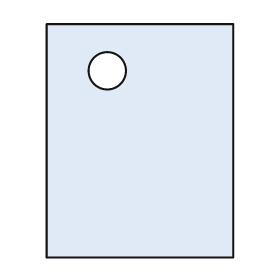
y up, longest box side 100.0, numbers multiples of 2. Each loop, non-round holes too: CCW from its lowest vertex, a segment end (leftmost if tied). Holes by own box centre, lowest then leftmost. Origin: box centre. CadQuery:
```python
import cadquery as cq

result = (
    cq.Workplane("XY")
    .moveTo(-40.0, -50.0)
    .lineTo(40.0, -50.0)
    .lineTo(40.0, 50.0)
    .lineTo(-40.0, 50.0)
    .close()
    .moveTo(-14.0, 30.0)
    .circle(8.0)
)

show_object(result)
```